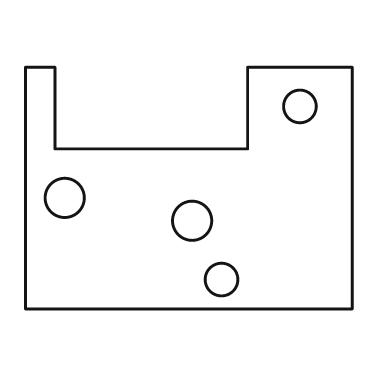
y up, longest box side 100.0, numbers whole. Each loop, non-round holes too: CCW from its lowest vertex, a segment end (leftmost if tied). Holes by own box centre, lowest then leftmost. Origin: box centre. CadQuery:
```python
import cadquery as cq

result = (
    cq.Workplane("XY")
    .moveTo(-50.0, -37.0)
    .lineTo(50.0, -37.0)
    .lineTo(50.0, 37.0)
    .lineTo(18.0, 37.0)
    .lineTo(18.0, 12.0)
    .lineTo(-41.0, 12.0)
    .lineTo(-41.0, 37.0)
    .lineTo(-50.0, 37.0)
    .close()
    .moveTo(10.0, -28.0)
    .circle(5.0)
    .moveTo(1.0, -10.0)
    .circle(6.0)
    .moveTo(-38.0, -3.0)
    .circle(6.0)
    .moveTo(34.0, 25.0)
    .circle(5.0)
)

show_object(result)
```